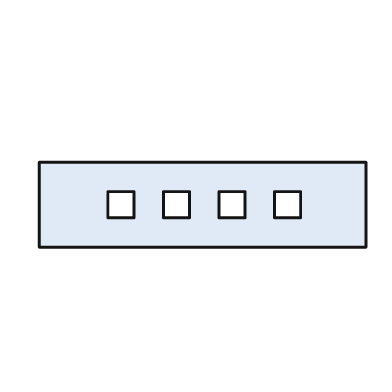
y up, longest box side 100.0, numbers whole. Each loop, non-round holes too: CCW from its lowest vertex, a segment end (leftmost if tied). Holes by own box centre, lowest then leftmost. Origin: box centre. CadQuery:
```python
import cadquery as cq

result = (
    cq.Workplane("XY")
    .moveTo(-50.0, -13.0)
    .lineTo(50.0, -13.0)
    .lineTo(50.0, 13.0)
    .lineTo(-50.0, 13.0)
    .close()
    .moveTo(-29.0, -4.0)
    .lineTo(-21.0, -4.0)
    .lineTo(-21.0, 4.0)
    .lineTo(-29.0, 4.0)
    .close()
    .moveTo(-12.0, -4.0)
    .lineTo(-4.0, -4.0)
    .lineTo(-4.0, 4.0)
    .lineTo(-12.0, 4.0)
    .close()
    .moveTo(5.0, -4.0)
    .lineTo(13.0, -4.0)
    .lineTo(13.0, 4.0)
    .lineTo(5.0, 4.0)
    .close()
    .moveTo(22.0, -4.0)
    .lineTo(30.0, -4.0)
    .lineTo(30.0, 4.0)
    .lineTo(22.0, 4.0)
    .close()
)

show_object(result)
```